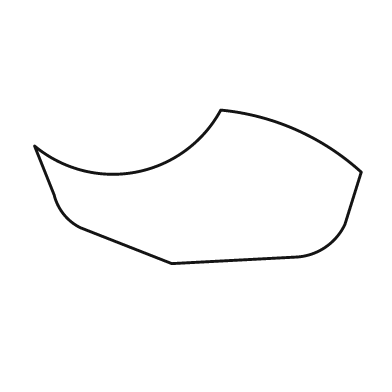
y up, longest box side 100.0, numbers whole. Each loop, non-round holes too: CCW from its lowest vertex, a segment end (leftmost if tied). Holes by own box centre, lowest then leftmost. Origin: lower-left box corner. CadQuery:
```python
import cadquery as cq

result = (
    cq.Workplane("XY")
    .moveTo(42.0, 0.0)
    .lineTo(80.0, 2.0)
    .threePointArc((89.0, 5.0), (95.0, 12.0))
    .lineTo(100.0, 28.0)
    .threePointArc((80.0, 41.0), (57.0, 47.0))
    .threePointArc((31.0, 28.0), (0.0, 36.0))
    .lineTo(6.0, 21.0)
    .threePointArc((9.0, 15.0), (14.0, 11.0))
    .close()
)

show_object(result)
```